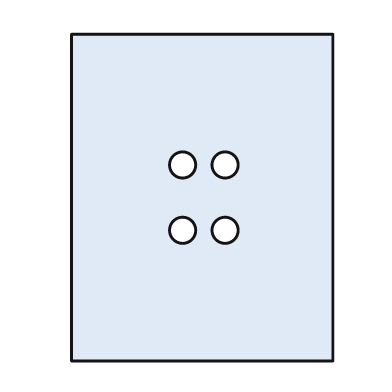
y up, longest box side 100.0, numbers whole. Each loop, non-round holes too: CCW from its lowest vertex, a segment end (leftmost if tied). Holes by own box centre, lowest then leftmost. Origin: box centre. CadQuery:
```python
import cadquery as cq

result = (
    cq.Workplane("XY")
    .moveTo(-40.0, -50.0)
    .lineTo(40.0, -50.0)
    .lineTo(40.0, 50.0)
    .lineTo(-40.0, 50.0)
    .close()
    .moveTo(-6.0, -10.0)
    .circle(4.0)
    .moveTo(7.0, -10.0)
    .circle(4.0)
    .moveTo(-6.0, 10.0)
    .circle(4.0)
    .moveTo(7.0, 10.0)
    .circle(4.0)
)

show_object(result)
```